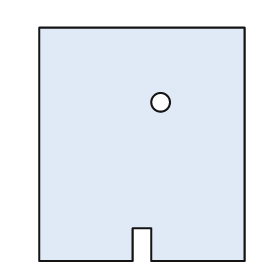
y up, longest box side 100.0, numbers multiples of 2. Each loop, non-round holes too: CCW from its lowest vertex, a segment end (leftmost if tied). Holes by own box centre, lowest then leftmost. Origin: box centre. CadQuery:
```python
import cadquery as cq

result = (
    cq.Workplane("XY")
    .moveTo(-44.0, -50.0)
    .lineTo(-4.0, -50.0)
    .lineTo(-4.0, -36.0)
    .lineTo(4.0, -36.0)
    .lineTo(4.0, -50.0)
    .lineTo(44.0, -50.0)
    .lineTo(44.0, 50.0)
    .lineTo(-44.0, 50.0)
    .close()
    .moveTo(8.0, 18.0)
    .circle(4.0)
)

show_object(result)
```